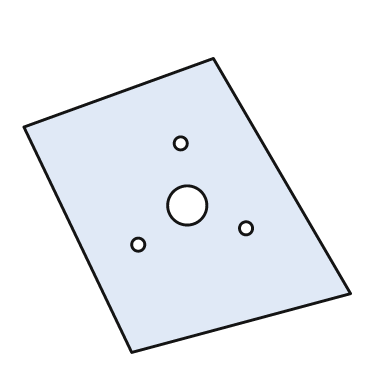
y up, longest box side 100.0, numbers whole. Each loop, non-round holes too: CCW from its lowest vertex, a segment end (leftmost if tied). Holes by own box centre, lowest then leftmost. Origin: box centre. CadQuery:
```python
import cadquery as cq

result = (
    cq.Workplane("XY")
    .moveTo(-17.0, -45.0)
    .lineTo(50.0, -27.0)
    .lineTo(8.0, 45.0)
    .lineTo(-50.0, 24.0)
    .close()
    .moveTo(-15.0, -12.0)
    .circle(2.0)
    .moveTo(18.0, -7.0)
    .circle(2.0)
    .moveTo(0.0, 0.0)
    .circle(6.0)
    .moveTo(-2.0, 19.0)
    .circle(2.0)
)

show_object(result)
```